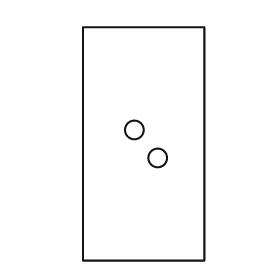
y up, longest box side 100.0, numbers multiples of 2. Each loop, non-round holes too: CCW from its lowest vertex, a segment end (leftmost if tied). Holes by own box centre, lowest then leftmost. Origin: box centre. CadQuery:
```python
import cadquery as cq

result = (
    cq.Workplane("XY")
    .moveTo(-26.0, -50.0)
    .lineTo(26.0, -50.0)
    .lineTo(26.0, 50.0)
    .lineTo(-26.0, 50.0)
    .close()
    .moveTo(6.0, -6.0)
    .circle(4.0)
    .moveTo(-4.0, 6.0)
    .circle(4.0)
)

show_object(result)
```